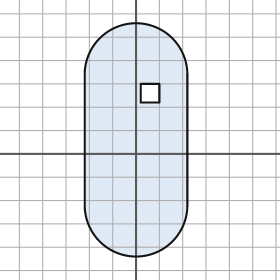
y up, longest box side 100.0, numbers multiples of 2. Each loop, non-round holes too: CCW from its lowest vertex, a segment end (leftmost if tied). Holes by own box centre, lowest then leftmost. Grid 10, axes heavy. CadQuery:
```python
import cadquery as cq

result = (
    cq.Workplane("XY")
    .moveTo(-22.0, -22.0)
    .threePointArc((0.0, -44.0), (22.0, -22.0))
    .lineTo(22.0, 34.0)
    .threePointArc((0.0, 56.0), (-22.0, 34.0))
    .close()
    .moveTo(2.0, 22.0)
    .lineTo(10.0, 22.0)
    .lineTo(10.0, 30.0)
    .lineTo(2.0, 30.0)
    .close()
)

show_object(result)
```